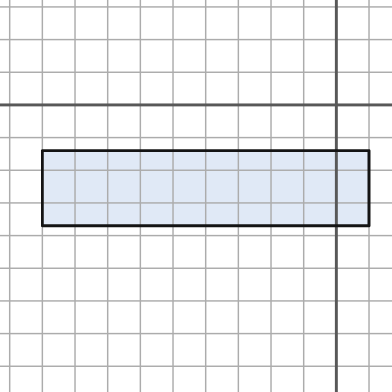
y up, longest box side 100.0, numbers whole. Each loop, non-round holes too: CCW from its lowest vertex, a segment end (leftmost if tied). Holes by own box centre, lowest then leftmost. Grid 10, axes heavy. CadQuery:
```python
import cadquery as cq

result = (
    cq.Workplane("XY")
    .moveTo(-90.0, -37.0)
    .lineTo(10.0, -37.0)
    .lineTo(10.0, -14.0)
    .lineTo(-90.0, -14.0)
    .close()
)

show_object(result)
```